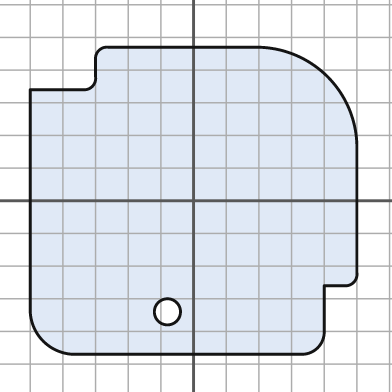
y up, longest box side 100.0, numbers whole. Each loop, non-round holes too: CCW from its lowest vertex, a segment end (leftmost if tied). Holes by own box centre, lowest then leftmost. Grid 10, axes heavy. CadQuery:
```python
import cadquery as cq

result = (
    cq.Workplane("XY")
    .moveTo(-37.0, -47.0)
    .lineTo(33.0, -47.0)
    .threePointArc((38.0, -45.0), (40.0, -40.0))
    .lineTo(40.0, -26.0)
    .lineTo(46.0, -26.0)
    .threePointArc((49.0, -25.0), (50.0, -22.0))
    .lineTo(50.0, 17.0)
    .threePointArc((41.0, 38.0), (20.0, 47.0))
    .lineTo(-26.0, 47.0)
    .threePointArc((-29.0, 46.0), (-30.0, 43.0))
    .lineTo(-30.0, 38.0)
    .threePointArc((-31.0, 35.0), (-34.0, 34.0))
    .lineTo(-50.0, 34.0)
    .lineTo(-50.0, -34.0)
    .threePointArc((-46.0, -43.0), (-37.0, -47.0))
    .close()
    .moveTo(-8.0, -34.0)
    .circle(4.0)
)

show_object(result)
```